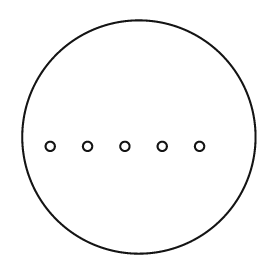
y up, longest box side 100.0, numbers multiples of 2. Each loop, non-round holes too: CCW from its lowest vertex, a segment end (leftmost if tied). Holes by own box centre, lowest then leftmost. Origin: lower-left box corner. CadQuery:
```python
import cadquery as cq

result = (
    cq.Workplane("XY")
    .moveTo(50.0, 50.0)
    .circle(50.0)
    .moveTo(12.0, 46.0)
    .circle(2.0)
    .moveTo(28.0, 46.0)
    .circle(2.0)
    .moveTo(44.0, 46.0)
    .circle(2.0)
    .moveTo(60.0, 46.0)
    .circle(2.0)
    .moveTo(76.0, 46.0)
    .circle(2.0)
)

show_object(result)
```